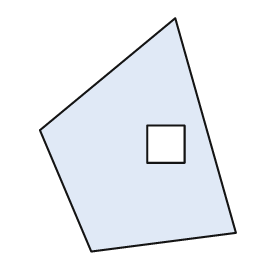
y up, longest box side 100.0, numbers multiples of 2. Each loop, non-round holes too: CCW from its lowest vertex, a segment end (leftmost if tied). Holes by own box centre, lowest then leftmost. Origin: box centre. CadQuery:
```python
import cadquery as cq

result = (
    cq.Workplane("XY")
    .moveTo(-20.0, -50.0)
    .lineTo(42.0, -42.0)
    .lineTo(16.0, 50.0)
    .lineTo(-42.0, 2.0)
    .close()
    .moveTo(4.0, -12.0)
    .lineTo(20.0, -12.0)
    .lineTo(20.0, 4.0)
    .lineTo(4.0, 4.0)
    .close()
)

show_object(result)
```